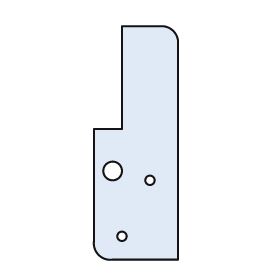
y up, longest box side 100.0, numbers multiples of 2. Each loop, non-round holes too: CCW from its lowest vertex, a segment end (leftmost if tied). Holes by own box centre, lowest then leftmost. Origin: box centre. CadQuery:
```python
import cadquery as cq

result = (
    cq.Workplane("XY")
    .moveTo(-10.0, -50.0)
    .lineTo(18.0, -50.0)
    .lineTo(18.0, 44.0)
    .threePointArc((16.0, 48.0), (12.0, 50.0))
    .lineTo(-6.0, 50.0)
    .lineTo(-6.0, 6.0)
    .lineTo(-18.0, 6.0)
    .lineTo(-18.0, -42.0)
    .threePointArc((-16.0, -48.0), (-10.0, -50.0))
    .close()
    .moveTo(-6.0, -40.0)
    .circle(2.0)
    .moveTo(6.0, -16.0)
    .circle(2.0)
    .moveTo(-10.0, -12.0)
    .circle(4.0)
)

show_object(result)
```